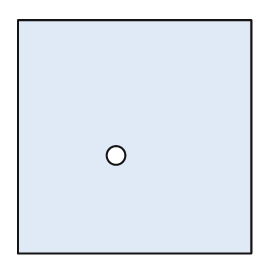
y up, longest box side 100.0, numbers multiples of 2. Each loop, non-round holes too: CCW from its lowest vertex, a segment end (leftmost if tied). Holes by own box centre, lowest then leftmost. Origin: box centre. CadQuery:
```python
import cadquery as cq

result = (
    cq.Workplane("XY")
    .moveTo(-50.0, -50.0)
    .lineTo(50.0, -50.0)
    .lineTo(50.0, 50.0)
    .lineTo(-50.0, 50.0)
    .close()
    .moveTo(-8.0, -8.0)
    .circle(4.0)
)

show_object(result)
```